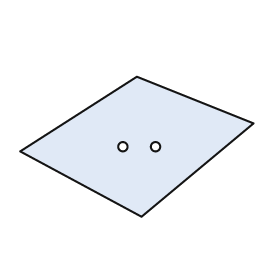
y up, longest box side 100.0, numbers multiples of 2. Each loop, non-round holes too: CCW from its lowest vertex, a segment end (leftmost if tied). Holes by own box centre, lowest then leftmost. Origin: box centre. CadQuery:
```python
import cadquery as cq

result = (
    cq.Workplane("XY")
    .moveTo(2.0, -30.0)
    .lineTo(50.0, 10.0)
    .lineTo(0.0, 30.0)
    .lineTo(-50.0, -2.0)
    .close()
    .moveTo(-6.0, 0.0)
    .circle(2.0)
    .moveTo(8.0, 0.0)
    .circle(2.0)
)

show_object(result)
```